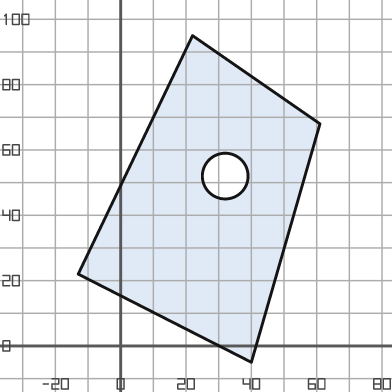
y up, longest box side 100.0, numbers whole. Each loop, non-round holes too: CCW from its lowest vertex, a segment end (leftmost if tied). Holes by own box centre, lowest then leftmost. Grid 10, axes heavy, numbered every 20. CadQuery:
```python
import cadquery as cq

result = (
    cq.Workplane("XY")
    .moveTo(40.0, -5.0)
    .lineTo(61.0, 68.0)
    .lineTo(22.0, 95.0)
    .lineTo(-13.0, 22.0)
    .close()
    .moveTo(32.0, 52.0)
    .circle(7.0)
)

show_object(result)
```